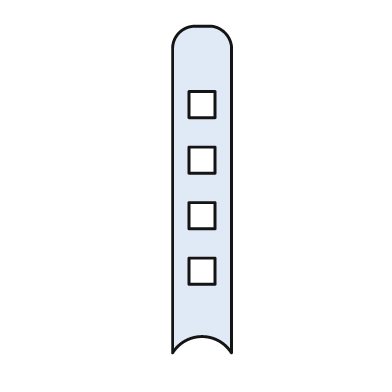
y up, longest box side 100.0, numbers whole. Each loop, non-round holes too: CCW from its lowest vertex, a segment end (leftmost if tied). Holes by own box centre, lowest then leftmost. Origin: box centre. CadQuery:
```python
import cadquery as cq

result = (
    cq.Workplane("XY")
    .moveTo(-9.0, -50.0)
    .threePointArc((0.0, -45.0), (9.0, -50.0))
    .lineTo(9.0, 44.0)
    .threePointArc((7.0, 48.0), (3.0, 50.0))
    .lineTo(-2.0, 50.0)
    .threePointArc((-7.0, 48.0), (-9.0, 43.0))
    .close()
    .moveTo(-4.0, -29.0)
    .lineTo(4.0, -29.0)
    .lineTo(4.0, -21.0)
    .lineTo(-4.0, -21.0)
    .close()
    .moveTo(-4.0, -12.0)
    .lineTo(4.0, -12.0)
    .lineTo(4.0, -4.0)
    .lineTo(-4.0, -4.0)
    .close()
    .moveTo(-4.0, 5.0)
    .lineTo(4.0, 5.0)
    .lineTo(4.0, 13.0)
    .lineTo(-4.0, 13.0)
    .close()
    .moveTo(-4.0, 22.0)
    .lineTo(4.0, 22.0)
    .lineTo(4.0, 30.0)
    .lineTo(-4.0, 30.0)
    .close()
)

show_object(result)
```